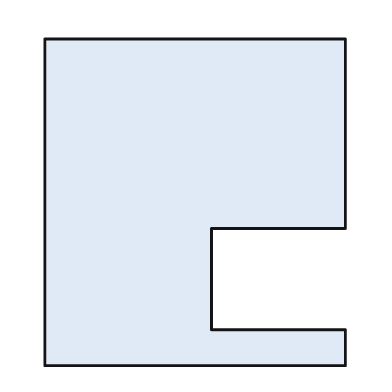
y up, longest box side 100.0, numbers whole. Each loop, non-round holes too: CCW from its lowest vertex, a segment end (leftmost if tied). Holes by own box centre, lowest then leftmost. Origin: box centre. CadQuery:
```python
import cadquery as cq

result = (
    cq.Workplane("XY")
    .moveTo(-46.0, -50.0)
    .lineTo(46.0, -50.0)
    .lineTo(46.0, -39.0)
    .lineTo(5.0, -39.0)
    .lineTo(5.0, -8.0)
    .lineTo(46.0, -8.0)
    .lineTo(46.0, 50.0)
    .lineTo(-46.0, 50.0)
    .close()
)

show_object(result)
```